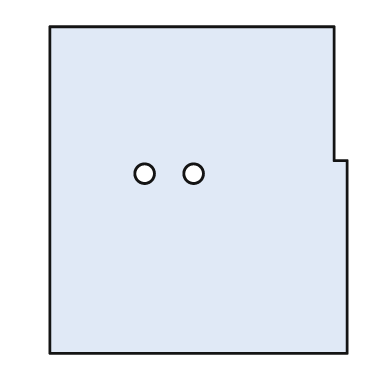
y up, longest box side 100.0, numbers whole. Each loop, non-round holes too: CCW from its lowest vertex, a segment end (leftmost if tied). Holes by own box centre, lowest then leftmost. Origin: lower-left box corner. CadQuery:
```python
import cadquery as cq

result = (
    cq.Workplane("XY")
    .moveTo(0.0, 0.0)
    .lineTo(91.0, 0.0)
    .lineTo(91.0, 59.0)
    .lineTo(87.0, 59.0)
    .lineTo(87.0, 100.0)
    .lineTo(0.0, 100.0)
    .close()
    .moveTo(29.0, 55.0)
    .circle(3.0)
    .moveTo(44.0, 55.0)
    .circle(3.0)
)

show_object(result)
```